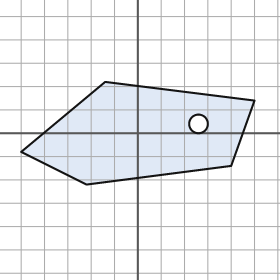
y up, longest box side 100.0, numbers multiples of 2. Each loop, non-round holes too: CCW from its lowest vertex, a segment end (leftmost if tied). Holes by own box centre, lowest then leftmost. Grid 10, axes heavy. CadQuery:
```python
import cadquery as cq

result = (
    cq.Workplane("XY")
    .moveTo(-22.0, -22.0)
    .lineTo(40.0, -14.0)
    .lineTo(50.0, 14.0)
    .lineTo(-14.0, 22.0)
    .lineTo(-50.0, -8.0)
    .close()
    .moveTo(26.0, 4.0)
    .circle(4.0)
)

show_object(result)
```